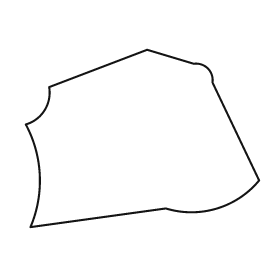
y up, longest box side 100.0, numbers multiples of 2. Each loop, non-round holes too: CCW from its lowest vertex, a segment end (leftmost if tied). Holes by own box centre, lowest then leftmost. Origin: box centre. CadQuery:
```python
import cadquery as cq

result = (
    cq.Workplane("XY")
    .moveTo(-48.0, -38.0)
    .lineTo(10.0, -30.0)
    .threePointArc((32.0, -30.0), (50.0, -18.0))
    .lineTo(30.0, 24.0)
    .threePointArc((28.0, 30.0), (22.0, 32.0))
    .lineTo(2.0, 38.0)
    .lineTo(-40.0, 22.0)
    .threePointArc((-42.0, 12.0), (-50.0, 6.0))
    .threePointArc((-44.0, -16.0), (-48.0, -38.0))
    .close()
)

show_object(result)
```